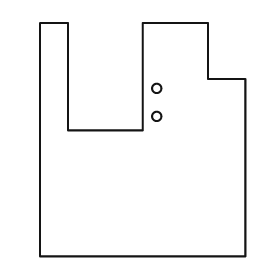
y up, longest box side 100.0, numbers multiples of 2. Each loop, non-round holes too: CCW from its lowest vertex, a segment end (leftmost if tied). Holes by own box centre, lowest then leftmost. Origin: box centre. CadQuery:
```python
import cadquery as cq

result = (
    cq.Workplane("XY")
    .moveTo(-44.0, -50.0)
    .lineTo(44.0, -50.0)
    .lineTo(44.0, 26.0)
    .lineTo(28.0, 26.0)
    .lineTo(28.0, 50.0)
    .lineTo(0.0, 50.0)
    .lineTo(0.0, 4.0)
    .lineTo(-32.0, 4.0)
    .lineTo(-32.0, 50.0)
    .lineTo(-44.0, 50.0)
    .close()
    .moveTo(6.0, 10.0)
    .circle(2.0)
    .moveTo(6.0, 22.0)
    .circle(2.0)
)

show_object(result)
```